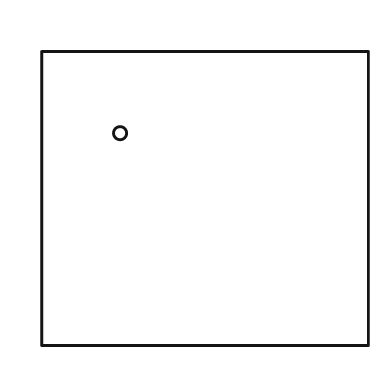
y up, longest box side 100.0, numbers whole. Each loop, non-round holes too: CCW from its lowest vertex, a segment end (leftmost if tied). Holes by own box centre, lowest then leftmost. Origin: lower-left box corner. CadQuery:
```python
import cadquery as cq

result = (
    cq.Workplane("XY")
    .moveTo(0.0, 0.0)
    .lineTo(100.0, 0.0)
    .lineTo(100.0, 90.0)
    .lineTo(0.0, 90.0)
    .close()
    .moveTo(24.0, 65.0)
    .circle(2.0)
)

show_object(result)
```